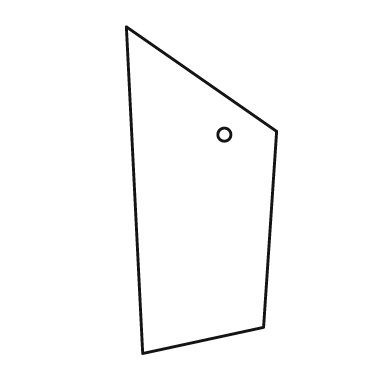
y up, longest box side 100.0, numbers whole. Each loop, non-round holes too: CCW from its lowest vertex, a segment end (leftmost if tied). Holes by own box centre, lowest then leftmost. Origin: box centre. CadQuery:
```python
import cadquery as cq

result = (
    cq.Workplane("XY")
    .moveTo(-18.0, -50.0)
    .lineTo(19.0, -42.0)
    .lineTo(23.0, 18.0)
    .lineTo(-23.0, 50.0)
    .close()
    .moveTo(7.0, 17.0)
    .circle(2.0)
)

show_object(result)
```